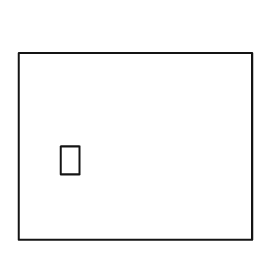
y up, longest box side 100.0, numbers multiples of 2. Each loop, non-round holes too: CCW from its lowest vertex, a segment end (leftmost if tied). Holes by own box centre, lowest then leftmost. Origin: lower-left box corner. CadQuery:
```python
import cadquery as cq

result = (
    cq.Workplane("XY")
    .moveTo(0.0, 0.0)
    .lineTo(100.0, 0.0)
    .lineTo(100.0, 80.0)
    .lineTo(0.0, 80.0)
    .close()
    .moveTo(18.0, 28.0)
    .lineTo(26.0, 28.0)
    .lineTo(26.0, 40.0)
    .lineTo(18.0, 40.0)
    .close()
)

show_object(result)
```